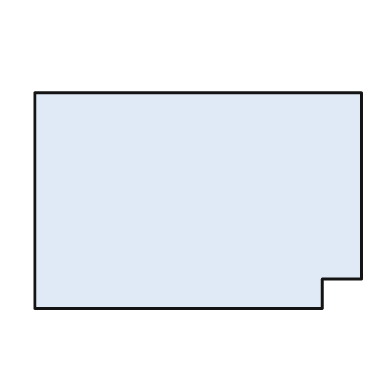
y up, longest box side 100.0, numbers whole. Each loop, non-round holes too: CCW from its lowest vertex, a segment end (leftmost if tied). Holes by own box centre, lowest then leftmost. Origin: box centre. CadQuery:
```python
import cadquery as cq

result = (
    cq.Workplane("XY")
    .moveTo(-50.0, -33.0)
    .lineTo(38.0, -33.0)
    .lineTo(38.0, -24.0)
    .lineTo(50.0, -24.0)
    .lineTo(50.0, 33.0)
    .lineTo(-50.0, 33.0)
    .close()
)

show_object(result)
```